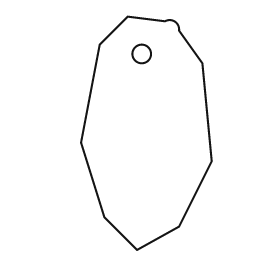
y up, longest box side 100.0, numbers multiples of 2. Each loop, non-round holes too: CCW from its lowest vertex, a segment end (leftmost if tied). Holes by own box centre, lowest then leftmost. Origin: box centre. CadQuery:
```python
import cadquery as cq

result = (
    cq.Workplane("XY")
    .moveTo(-4.0, -50.0)
    .lineTo(14.0, -40.0)
    .lineTo(28.0, -12.0)
    .lineTo(24.0, 30.0)
    .lineTo(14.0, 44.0)
    .threePointArc((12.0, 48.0), (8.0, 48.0))
    .lineTo(-8.0, 50.0)
    .lineTo(-20.0, 38.0)
    .lineTo(-28.0, -4.0)
    .lineTo(-18.0, -36.0)
    .close()
    .moveTo(-2.0, 34.0)
    .circle(4.0)
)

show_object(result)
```